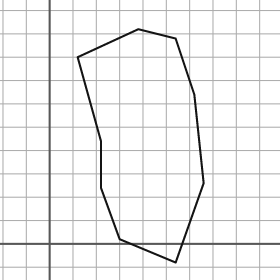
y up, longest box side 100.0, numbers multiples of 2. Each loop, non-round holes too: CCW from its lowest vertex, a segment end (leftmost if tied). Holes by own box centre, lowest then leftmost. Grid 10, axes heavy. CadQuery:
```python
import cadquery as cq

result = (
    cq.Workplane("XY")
    .moveTo(54.0, -8.0)
    .lineTo(66.0, 26.0)
    .lineTo(62.0, 64.0)
    .lineTo(54.0, 88.0)
    .lineTo(38.0, 92.0)
    .lineTo(12.0, 80.0)
    .lineTo(22.0, 44.0)
    .lineTo(22.0, 24.0)
    .lineTo(30.0, 2.0)
    .close()
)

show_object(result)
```